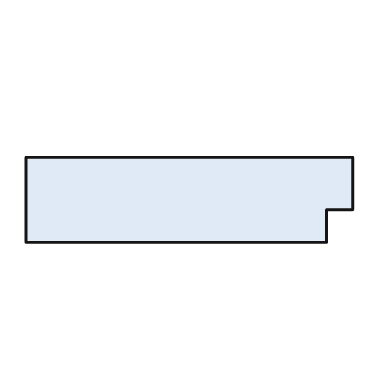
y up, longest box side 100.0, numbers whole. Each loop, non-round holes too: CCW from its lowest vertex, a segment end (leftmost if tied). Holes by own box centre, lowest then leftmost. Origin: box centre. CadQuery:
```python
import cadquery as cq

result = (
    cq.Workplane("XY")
    .moveTo(-50.0, -13.0)
    .lineTo(42.0, -13.0)
    .lineTo(42.0, -3.0)
    .lineTo(50.0, -3.0)
    .lineTo(50.0, 13.0)
    .lineTo(-50.0, 13.0)
    .close()
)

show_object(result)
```